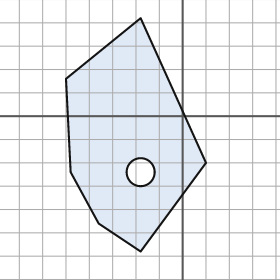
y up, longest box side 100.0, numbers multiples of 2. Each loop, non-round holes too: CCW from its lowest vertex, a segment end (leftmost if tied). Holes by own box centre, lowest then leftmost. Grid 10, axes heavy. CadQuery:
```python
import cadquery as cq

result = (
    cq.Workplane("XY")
    .moveTo(-18.0, -58.0)
    .lineTo(10.0, -20.0)
    .lineTo(-18.0, 42.0)
    .lineTo(-50.0, 16.0)
    .lineTo(-48.0, -24.0)
    .lineTo(-36.0, -46.0)
    .close()
    .moveTo(-18.0, -24.0)
    .circle(6.0)
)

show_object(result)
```